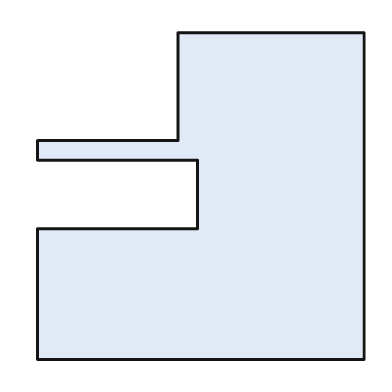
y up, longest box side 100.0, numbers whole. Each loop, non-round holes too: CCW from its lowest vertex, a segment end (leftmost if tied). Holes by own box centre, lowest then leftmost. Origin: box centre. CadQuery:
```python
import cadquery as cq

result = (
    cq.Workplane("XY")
    .moveTo(-50.0, -50.0)
    .lineTo(50.0, -50.0)
    .lineTo(50.0, 50.0)
    .lineTo(-7.0, 50.0)
    .lineTo(-7.0, 17.0)
    .lineTo(-50.0, 17.0)
    .lineTo(-50.0, 11.0)
    .lineTo(-1.0, 11.0)
    .lineTo(-1.0, -10.0)
    .lineTo(-50.0, -10.0)
    .close()
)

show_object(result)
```